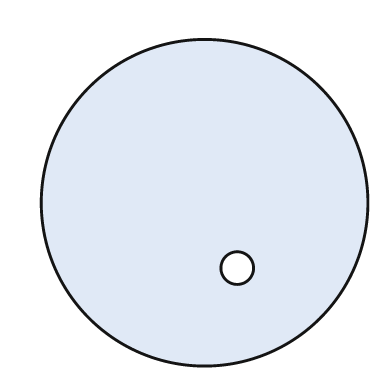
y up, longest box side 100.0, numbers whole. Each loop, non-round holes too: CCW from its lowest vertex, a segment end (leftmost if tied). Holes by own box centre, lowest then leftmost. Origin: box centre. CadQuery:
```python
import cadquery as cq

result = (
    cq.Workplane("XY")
    .moveTo(0.0, 0.0)
    .circle(50.0)
    .moveTo(10.0, -20.0)
    .circle(5.0)
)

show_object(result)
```